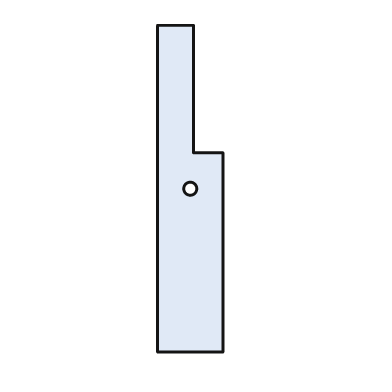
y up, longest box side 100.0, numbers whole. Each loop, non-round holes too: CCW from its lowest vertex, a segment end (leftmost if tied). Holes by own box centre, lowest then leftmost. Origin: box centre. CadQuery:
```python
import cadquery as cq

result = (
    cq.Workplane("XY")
    .moveTo(-10.0, -50.0)
    .lineTo(10.0, -50.0)
    .lineTo(10.0, 11.0)
    .lineTo(1.0, 11.0)
    .lineTo(1.0, 50.0)
    .lineTo(-10.0, 50.0)
    .close()
    .moveTo(0.0, 0.0)
    .circle(2.0)
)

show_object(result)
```